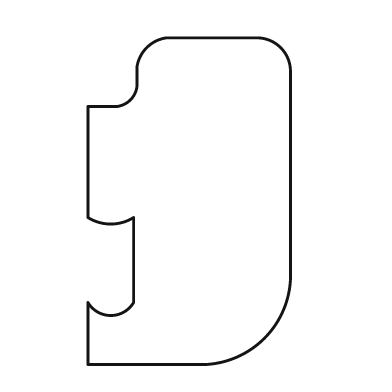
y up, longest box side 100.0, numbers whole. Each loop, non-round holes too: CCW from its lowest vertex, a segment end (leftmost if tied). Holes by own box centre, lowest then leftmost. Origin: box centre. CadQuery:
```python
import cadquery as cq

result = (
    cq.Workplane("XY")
    .moveTo(-31.0, -50.0)
    .lineTo(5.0, -50.0)
    .threePointArc((23.0, -42.0), (31.0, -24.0))
    .lineTo(31.0, 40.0)
    .threePointArc((28.0, 47.0), (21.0, 50.0))
    .lineTo(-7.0, 50.0)
    .threePointArc((-13.0, 47.0), (-16.0, 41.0))
    .lineTo(-16.0, 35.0)
    .threePointArc((-18.0, 31.0), (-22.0, 29.0))
    .lineTo(-31.0, 29.0)
    .lineTo(-31.0, -5.0)
    .threePointArc((-24.0, -7.0), (-17.0, -5.0))
    .lineTo(-17.0, -31.0)
    .threePointArc((-24.0, -35.0), (-31.0, -31.0))
    .close()
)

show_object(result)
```